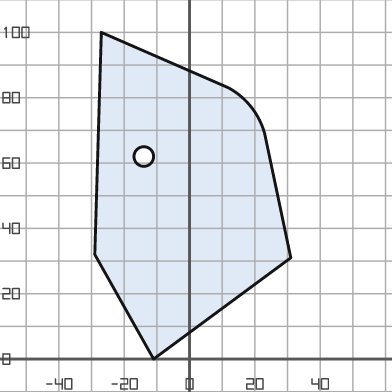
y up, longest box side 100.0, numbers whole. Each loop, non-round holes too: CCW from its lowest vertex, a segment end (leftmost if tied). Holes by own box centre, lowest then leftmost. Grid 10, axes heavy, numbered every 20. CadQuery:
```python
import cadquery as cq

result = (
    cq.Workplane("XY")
    .moveTo(-11.0, 0.0)
    .lineTo(31.0, 31.0)
    .lineTo(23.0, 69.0)
    .threePointArc((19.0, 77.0), (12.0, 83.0))
    .lineTo(-27.0, 100.0)
    .lineTo(-29.0, 32.0)
    .close()
    .moveTo(-14.0, 62.0)
    .circle(3.0)
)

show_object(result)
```